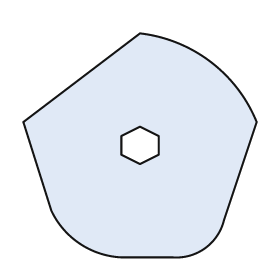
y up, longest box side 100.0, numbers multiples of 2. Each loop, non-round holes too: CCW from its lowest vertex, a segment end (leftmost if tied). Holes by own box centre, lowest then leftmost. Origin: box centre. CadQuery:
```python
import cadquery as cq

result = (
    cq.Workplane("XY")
    .moveTo(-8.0, -48.0)
    .lineTo(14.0, -48.0)
    .threePointArc((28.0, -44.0), (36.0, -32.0))
    .lineTo(50.0, 10.0)
    .threePointArc((30.0, 36.0), (0.0, 48.0))
    .lineTo(-50.0, 10.0)
    .lineTo(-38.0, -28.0)
    .threePointArc((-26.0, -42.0), (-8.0, -48.0))
    .close()
    .moveTo(0.0, -8.0)
    .lineTo(8.0, -4.0)
    .lineTo(8.0, 4.0)
    .lineTo(0.0, 8.0)
    .lineTo(-8.0, 4.0)
    .lineTo(-8.0, -4.0)
    .close()
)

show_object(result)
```